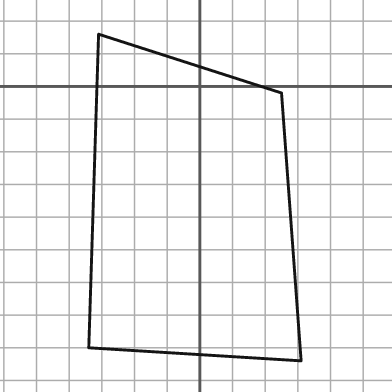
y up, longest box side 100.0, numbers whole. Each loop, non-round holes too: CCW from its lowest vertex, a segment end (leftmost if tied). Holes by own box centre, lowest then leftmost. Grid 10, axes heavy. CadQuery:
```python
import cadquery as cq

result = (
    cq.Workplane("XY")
    .moveTo(31.0, -84.0)
    .lineTo(25.0, -2.0)
    .lineTo(-31.0, 16.0)
    .lineTo(-34.0, -80.0)
    .close()
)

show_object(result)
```